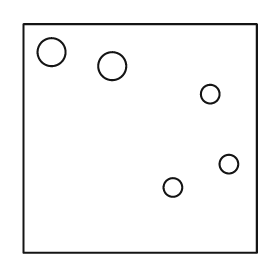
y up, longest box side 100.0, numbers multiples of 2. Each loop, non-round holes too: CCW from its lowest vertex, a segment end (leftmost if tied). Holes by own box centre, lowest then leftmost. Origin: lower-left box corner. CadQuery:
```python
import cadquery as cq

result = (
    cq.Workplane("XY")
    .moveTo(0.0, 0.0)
    .lineTo(100.0, 0.0)
    .lineTo(100.0, 98.0)
    .lineTo(0.0, 98.0)
    .close()
    .moveTo(64.0, 28.0)
    .circle(4.0)
    .moveTo(88.0, 38.0)
    .circle(4.0)
    .moveTo(80.0, 68.0)
    .circle(4.0)
    .moveTo(38.0, 80.0)
    .circle(6.0)
    .moveTo(12.0, 86.0)
    .circle(6.0)
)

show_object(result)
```